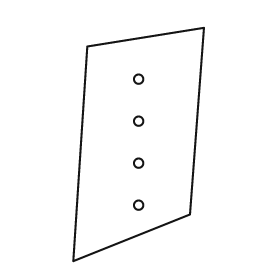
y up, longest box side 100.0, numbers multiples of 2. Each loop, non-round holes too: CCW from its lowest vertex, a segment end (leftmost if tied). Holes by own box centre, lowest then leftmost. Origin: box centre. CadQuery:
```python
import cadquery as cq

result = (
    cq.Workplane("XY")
    .moveTo(-28.0, -50.0)
    .lineTo(22.0, -30.0)
    .lineTo(28.0, 50.0)
    .lineTo(-22.0, 42.0)
    .close()
    .moveTo(0.0, -26.0)
    .circle(2.0)
    .moveTo(0.0, -8.0)
    .circle(2.0)
    .moveTo(0.0, 10.0)
    .circle(2.0)
    .moveTo(0.0, 28.0)
    .circle(2.0)
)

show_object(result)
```